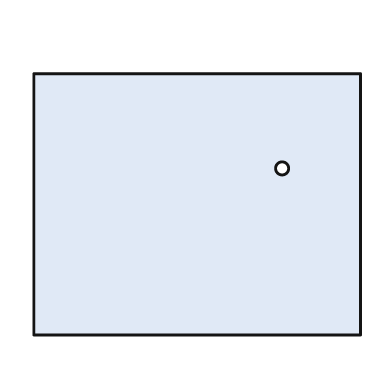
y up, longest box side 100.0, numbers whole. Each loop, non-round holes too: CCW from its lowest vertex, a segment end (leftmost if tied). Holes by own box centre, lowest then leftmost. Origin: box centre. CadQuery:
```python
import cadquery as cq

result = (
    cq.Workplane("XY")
    .moveTo(-50.0, -40.0)
    .lineTo(50.0, -40.0)
    .lineTo(50.0, 40.0)
    .lineTo(-50.0, 40.0)
    .close()
    .moveTo(26.0, 11.0)
    .circle(2.0)
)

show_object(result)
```